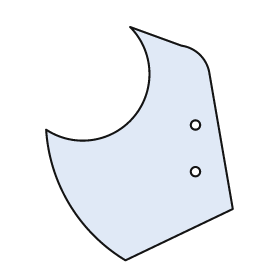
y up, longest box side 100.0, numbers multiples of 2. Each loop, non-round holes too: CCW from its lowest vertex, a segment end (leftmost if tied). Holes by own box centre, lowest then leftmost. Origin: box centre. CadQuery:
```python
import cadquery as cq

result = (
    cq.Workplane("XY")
    .moveTo(-6.0, -50.0)
    .lineTo(40.0, -28.0)
    .lineTo(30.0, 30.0)
    .threePointArc((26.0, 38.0), (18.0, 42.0))
    .lineTo(-4.0, 50.0)
    .threePointArc((-2.0, 12.0), (-40.0, 6.0))
    .threePointArc((-30.0, -26.0), (-6.0, -50.0))
    .close()
    .moveTo(24.0, -12.0)
    .circle(2.0)
    .moveTo(24.0, 8.0)
    .circle(2.0)
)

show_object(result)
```